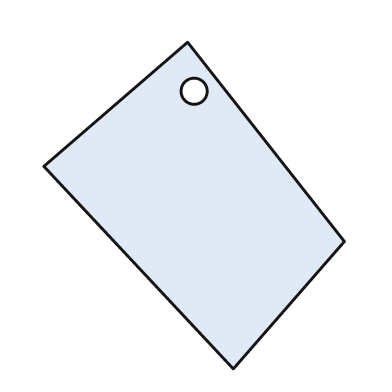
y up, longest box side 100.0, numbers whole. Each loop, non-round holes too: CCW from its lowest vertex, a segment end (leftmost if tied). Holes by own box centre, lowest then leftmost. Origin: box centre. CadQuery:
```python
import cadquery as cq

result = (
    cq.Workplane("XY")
    .moveTo(12.0, -50.0)
    .lineTo(46.0, -11.0)
    .lineTo(-2.0, 50.0)
    .lineTo(-46.0, 12.0)
    .close()
    .moveTo(0.0, 35.0)
    .circle(4.0)
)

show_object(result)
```